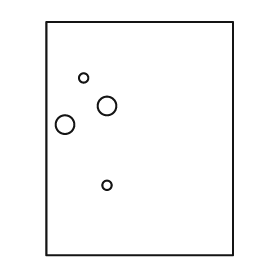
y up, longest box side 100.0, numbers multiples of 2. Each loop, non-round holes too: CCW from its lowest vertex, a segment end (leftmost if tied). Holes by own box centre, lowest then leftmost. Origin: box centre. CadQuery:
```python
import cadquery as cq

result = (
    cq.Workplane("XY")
    .moveTo(-40.0, -50.0)
    .lineTo(40.0, -50.0)
    .lineTo(40.0, 50.0)
    .lineTo(-40.0, 50.0)
    .close()
    .moveTo(-14.0, -20.0)
    .circle(2.0)
    .moveTo(-32.0, 6.0)
    .circle(4.0)
    .moveTo(-14.0, 14.0)
    .circle(4.0)
    .moveTo(-24.0, 26.0)
    .circle(2.0)
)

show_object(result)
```